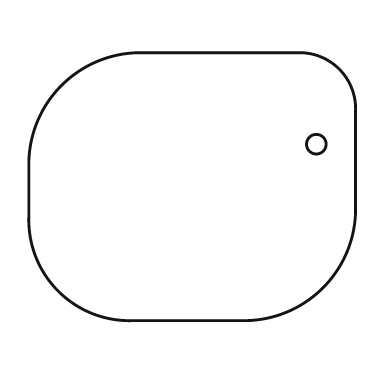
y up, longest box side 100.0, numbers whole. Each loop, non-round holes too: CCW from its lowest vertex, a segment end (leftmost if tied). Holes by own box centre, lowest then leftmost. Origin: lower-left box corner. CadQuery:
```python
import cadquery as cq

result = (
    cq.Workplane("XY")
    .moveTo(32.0, 0.0)
    .lineTo(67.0, 0.0)
    .threePointArc((90.0, 10.0), (100.0, 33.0))
    .lineTo(100.0, 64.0)
    .threePointArc((95.0, 77.0), (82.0, 82.0))
    .lineTo(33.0, 82.0)
    .threePointArc((10.0, 72.0), (0.0, 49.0))
    .lineTo(0.0, 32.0)
    .threePointArc((9.0, 9.0), (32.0, 0.0))
    .close()
    .moveTo(88.0, 54.0)
    .circle(3.0)
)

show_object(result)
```